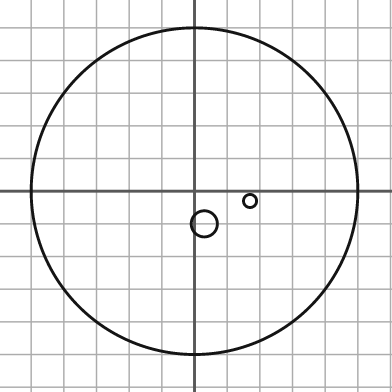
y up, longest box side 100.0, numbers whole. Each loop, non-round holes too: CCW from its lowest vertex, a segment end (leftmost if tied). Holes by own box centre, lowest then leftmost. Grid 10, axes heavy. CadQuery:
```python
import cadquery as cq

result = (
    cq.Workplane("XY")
    .moveTo(0.0, 0.0)
    .circle(50.0)
    .moveTo(3.0, -10.0)
    .circle(4.0)
    .moveTo(17.0, -3.0)
    .circle(2.0)
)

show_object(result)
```